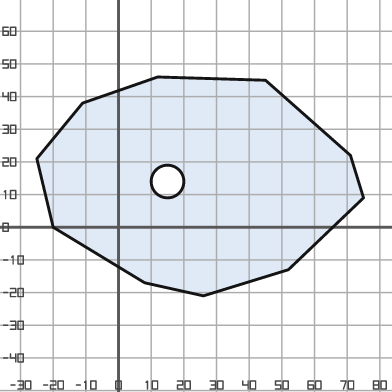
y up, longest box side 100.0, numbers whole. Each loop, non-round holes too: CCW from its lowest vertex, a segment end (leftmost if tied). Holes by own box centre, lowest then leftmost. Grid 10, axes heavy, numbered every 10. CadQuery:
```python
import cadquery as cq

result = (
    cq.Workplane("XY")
    .moveTo(26.0, -21.0)
    .lineTo(52.0, -13.0)
    .lineTo(75.0, 9.0)
    .lineTo(71.0, 22.0)
    .lineTo(45.0, 45.0)
    .lineTo(12.0, 46.0)
    .lineTo(-11.0, 38.0)
    .lineTo(-25.0, 21.0)
    .lineTo(-20.0, 0.0)
    .lineTo(8.0, -17.0)
    .close()
    .moveTo(15.0, 14.0)
    .circle(5.0)
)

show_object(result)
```